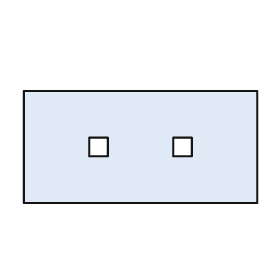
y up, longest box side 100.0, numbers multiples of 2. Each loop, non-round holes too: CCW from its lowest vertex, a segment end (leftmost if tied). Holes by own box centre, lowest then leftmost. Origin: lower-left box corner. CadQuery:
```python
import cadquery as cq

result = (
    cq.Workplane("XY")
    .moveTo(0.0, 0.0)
    .lineTo(100.0, 0.0)
    .lineTo(100.0, 48.0)
    .lineTo(0.0, 48.0)
    .close()
    .moveTo(28.0, 20.0)
    .lineTo(36.0, 20.0)
    .lineTo(36.0, 28.0)
    .lineTo(28.0, 28.0)
    .close()
    .moveTo(64.0, 20.0)
    .lineTo(72.0, 20.0)
    .lineTo(72.0, 28.0)
    .lineTo(64.0, 28.0)
    .close()
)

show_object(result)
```